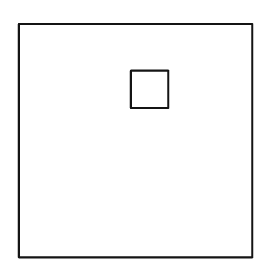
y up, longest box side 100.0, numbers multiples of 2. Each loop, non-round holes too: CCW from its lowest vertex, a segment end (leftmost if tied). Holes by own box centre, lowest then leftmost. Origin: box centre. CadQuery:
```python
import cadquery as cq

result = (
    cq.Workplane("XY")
    .moveTo(-50.0, -50.0)
    .lineTo(50.0, -50.0)
    .lineTo(50.0, 50.0)
    .lineTo(-50.0, 50.0)
    .close()
    .moveTo(-2.0, 14.0)
    .lineTo(14.0, 14.0)
    .lineTo(14.0, 30.0)
    .lineTo(-2.0, 30.0)
    .close()
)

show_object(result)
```